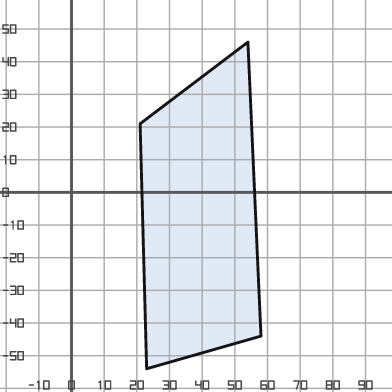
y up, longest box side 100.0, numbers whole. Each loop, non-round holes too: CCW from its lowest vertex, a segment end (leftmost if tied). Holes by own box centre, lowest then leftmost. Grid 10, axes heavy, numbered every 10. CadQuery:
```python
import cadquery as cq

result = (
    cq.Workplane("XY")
    .moveTo(23.0, -54.0)
    .lineTo(58.0, -44.0)
    .lineTo(54.0, 46.0)
    .lineTo(21.0, 21.0)
    .close()
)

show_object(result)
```